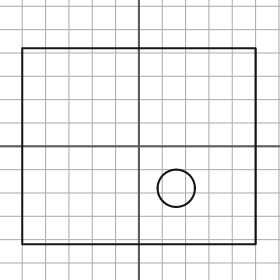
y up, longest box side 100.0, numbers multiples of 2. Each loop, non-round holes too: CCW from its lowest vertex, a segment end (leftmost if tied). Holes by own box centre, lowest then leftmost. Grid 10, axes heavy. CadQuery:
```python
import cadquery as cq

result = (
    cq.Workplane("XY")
    .moveTo(-50.0, -42.0)
    .lineTo(50.0, -42.0)
    .lineTo(50.0, 42.0)
    .lineTo(-50.0, 42.0)
    .close()
    .moveTo(16.0, -18.0)
    .circle(8.0)
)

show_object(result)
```